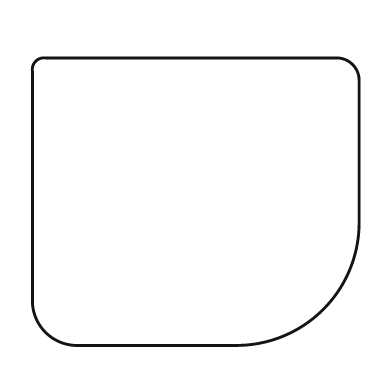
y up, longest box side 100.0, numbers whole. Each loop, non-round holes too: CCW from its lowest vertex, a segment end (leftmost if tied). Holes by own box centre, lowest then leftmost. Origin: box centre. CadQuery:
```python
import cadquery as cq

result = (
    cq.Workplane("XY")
    .moveTo(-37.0, -44.0)
    .lineTo(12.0, -44.0)
    .threePointArc((39.0, -33.0), (50.0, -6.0))
    .lineTo(50.0, 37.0)
    .threePointArc((48.0, 42.0), (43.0, 44.0))
    .lineTo(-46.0, 44.0)
    .threePointArc((-49.0, 43.0), (-50.0, 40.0))
    .lineTo(-50.0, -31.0)
    .threePointArc((-46.0, -40.0), (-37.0, -44.0))
    .close()
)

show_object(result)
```